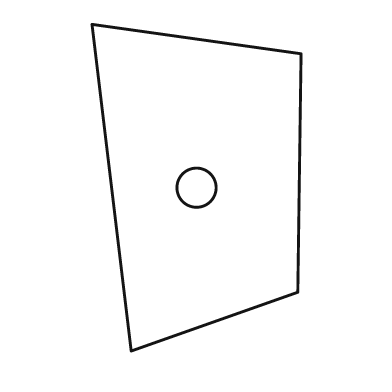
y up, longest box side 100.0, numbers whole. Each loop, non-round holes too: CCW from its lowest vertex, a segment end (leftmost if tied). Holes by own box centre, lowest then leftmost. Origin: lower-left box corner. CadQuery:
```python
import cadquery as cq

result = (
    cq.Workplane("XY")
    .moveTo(12.0, 0.0)
    .lineTo(63.0, 18.0)
    .lineTo(64.0, 91.0)
    .lineTo(0.0, 100.0)
    .close()
    .moveTo(32.0, 50.0)
    .circle(6.0)
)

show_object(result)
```